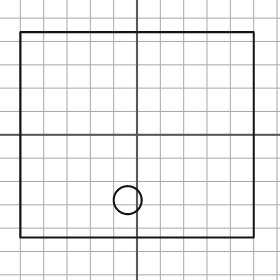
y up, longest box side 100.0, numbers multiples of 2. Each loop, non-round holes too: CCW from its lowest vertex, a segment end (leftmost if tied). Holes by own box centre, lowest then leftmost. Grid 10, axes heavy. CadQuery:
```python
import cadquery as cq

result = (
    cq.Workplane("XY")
    .moveTo(-50.0, -44.0)
    .lineTo(50.0, -44.0)
    .lineTo(50.0, 44.0)
    .lineTo(-50.0, 44.0)
    .close()
    .moveTo(-4.0, -28.0)
    .circle(6.0)
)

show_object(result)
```